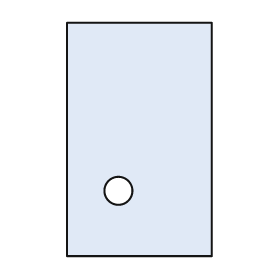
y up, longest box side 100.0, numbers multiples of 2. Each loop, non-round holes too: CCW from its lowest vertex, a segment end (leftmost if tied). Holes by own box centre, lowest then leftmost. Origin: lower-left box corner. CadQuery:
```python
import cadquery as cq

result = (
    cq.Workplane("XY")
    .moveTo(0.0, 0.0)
    .lineTo(62.0, 0.0)
    .lineTo(62.0, 100.0)
    .lineTo(0.0, 100.0)
    .close()
    .moveTo(22.0, 28.0)
    .circle(6.0)
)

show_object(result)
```